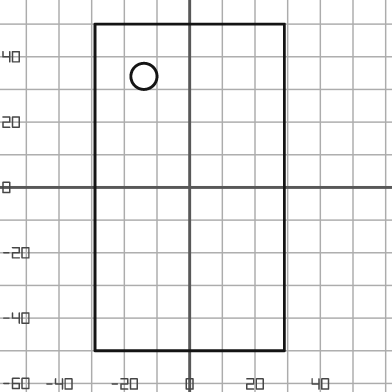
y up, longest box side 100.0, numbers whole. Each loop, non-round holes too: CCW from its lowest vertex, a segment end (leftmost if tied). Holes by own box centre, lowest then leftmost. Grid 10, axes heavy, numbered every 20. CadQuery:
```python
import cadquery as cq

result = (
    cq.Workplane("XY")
    .moveTo(-29.0, -50.0)
    .lineTo(29.0, -50.0)
    .lineTo(29.0, 50.0)
    .lineTo(-29.0, 50.0)
    .close()
    .moveTo(-14.0, 34.0)
    .circle(4.0)
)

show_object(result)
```